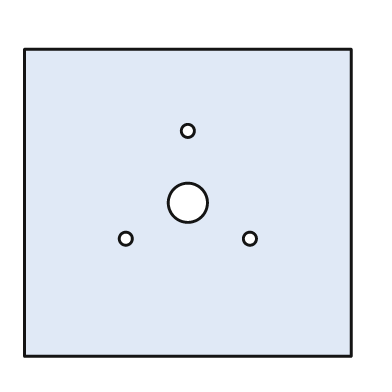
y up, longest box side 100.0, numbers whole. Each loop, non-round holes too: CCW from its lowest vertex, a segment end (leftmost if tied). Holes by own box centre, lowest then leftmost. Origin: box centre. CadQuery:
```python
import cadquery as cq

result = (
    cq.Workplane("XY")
    .moveTo(-50.0, -47.0)
    .lineTo(50.0, -47.0)
    .lineTo(50.0, 47.0)
    .lineTo(-50.0, 47.0)
    .close()
    .moveTo(-19.0, -11.0)
    .circle(2.0)
    .moveTo(19.0, -11.0)
    .circle(2.0)
    .moveTo(0.0, 0.0)
    .circle(6.0)
    .moveTo(0.0, 22.0)
    .circle(2.0)
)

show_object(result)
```